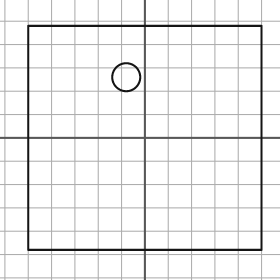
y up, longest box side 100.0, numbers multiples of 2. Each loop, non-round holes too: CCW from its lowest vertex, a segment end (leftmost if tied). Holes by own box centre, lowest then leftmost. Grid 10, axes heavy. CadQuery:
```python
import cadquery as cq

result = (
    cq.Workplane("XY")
    .moveTo(-50.0, -48.0)
    .lineTo(50.0, -48.0)
    .lineTo(50.0, 48.0)
    .lineTo(-50.0, 48.0)
    .close()
    .moveTo(-8.0, 26.0)
    .circle(6.0)
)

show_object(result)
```